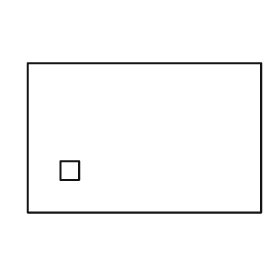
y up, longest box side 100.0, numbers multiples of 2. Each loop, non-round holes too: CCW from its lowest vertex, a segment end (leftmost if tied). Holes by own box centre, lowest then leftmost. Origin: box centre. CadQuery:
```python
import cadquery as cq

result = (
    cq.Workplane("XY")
    .moveTo(-50.0, -32.0)
    .lineTo(50.0, -32.0)
    .lineTo(50.0, 32.0)
    .lineTo(-50.0, 32.0)
    .close()
    .moveTo(-36.0, -18.0)
    .lineTo(-28.0, -18.0)
    .lineTo(-28.0, -10.0)
    .lineTo(-36.0, -10.0)
    .close()
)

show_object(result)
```